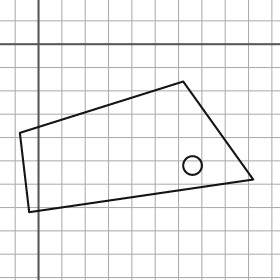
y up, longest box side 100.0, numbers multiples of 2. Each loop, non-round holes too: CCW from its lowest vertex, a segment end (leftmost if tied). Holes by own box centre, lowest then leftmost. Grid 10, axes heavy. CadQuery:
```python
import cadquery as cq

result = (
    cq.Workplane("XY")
    .moveTo(-4.0, -72.0)
    .lineTo(92.0, -58.0)
    .lineTo(62.0, -16.0)
    .lineTo(-8.0, -38.0)
    .close()
    .moveTo(66.0, -52.0)
    .circle(4.0)
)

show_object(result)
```